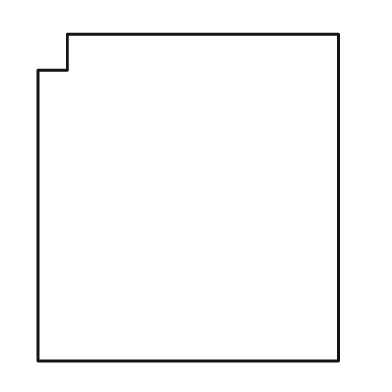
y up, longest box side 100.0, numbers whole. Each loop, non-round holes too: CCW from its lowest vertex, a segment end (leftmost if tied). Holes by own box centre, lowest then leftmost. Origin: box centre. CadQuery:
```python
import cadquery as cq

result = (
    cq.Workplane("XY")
    .moveTo(-46.0, -50.0)
    .lineTo(46.0, -50.0)
    .lineTo(46.0, 50.0)
    .lineTo(-37.0, 50.0)
    .lineTo(-37.0, 39.0)
    .lineTo(-46.0, 39.0)
    .close()
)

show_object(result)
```